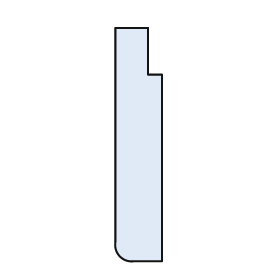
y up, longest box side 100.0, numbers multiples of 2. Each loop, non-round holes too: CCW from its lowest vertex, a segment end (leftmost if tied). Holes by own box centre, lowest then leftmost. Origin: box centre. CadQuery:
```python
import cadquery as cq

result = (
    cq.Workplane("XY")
    .moveTo(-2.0, -50.0)
    .lineTo(10.0, -50.0)
    .lineTo(10.0, 30.0)
    .lineTo(4.0, 30.0)
    .lineTo(4.0, 50.0)
    .lineTo(-10.0, 50.0)
    .lineTo(-10.0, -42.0)
    .threePointArc((-8.0, -48.0), (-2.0, -50.0))
    .close()
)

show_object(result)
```